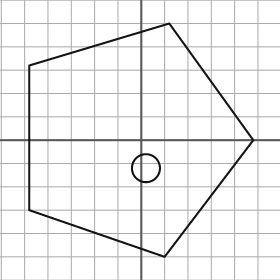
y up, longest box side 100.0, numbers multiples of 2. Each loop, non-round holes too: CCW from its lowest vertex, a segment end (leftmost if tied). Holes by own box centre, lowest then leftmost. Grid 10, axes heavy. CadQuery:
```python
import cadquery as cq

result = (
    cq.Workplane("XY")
    .moveTo(10.0, -50.0)
    .lineTo(48.0, 0.0)
    .lineTo(12.0, 50.0)
    .lineTo(-48.0, 32.0)
    .lineTo(-48.0, -30.0)
    .close()
    .moveTo(2.0, -12.0)
    .circle(6.0)
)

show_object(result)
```